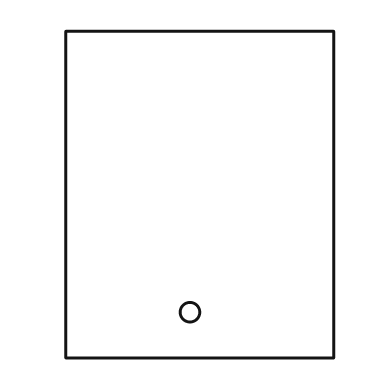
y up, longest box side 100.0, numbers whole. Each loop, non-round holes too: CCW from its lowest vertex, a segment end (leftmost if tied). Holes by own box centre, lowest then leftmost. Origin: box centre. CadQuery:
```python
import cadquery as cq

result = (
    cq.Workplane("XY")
    .moveTo(-41.0, -50.0)
    .lineTo(41.0, -50.0)
    .lineTo(41.0, 50.0)
    .lineTo(-41.0, 50.0)
    .close()
    .moveTo(-3.0, -36.0)
    .circle(3.0)
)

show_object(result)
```